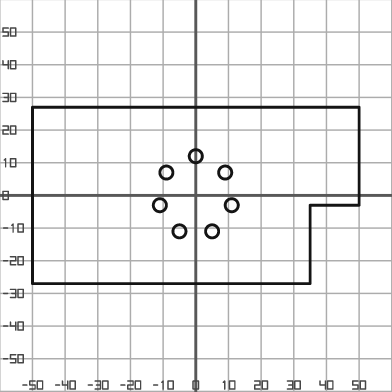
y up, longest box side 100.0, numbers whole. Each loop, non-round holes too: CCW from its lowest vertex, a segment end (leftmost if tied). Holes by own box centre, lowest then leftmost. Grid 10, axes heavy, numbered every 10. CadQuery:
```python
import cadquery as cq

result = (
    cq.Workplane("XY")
    .moveTo(-50.0, -27.0)
    .lineTo(35.0, -27.0)
    .lineTo(35.0, -3.0)
    .lineTo(50.0, -3.0)
    .lineTo(50.0, 27.0)
    .lineTo(-50.0, 27.0)
    .close()
    .moveTo(-5.0, -11.0)
    .circle(2.0)
    .moveTo(5.0, -11.0)
    .circle(2.0)
    .moveTo(-11.0, -3.0)
    .circle(2.0)
    .moveTo(11.0, -3.0)
    .circle(2.0)
    .moveTo(-9.0, 7.0)
    .circle(2.0)
    .moveTo(9.0, 7.0)
    .circle(2.0)
    .moveTo(0.0, 12.0)
    .circle(2.0)
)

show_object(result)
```